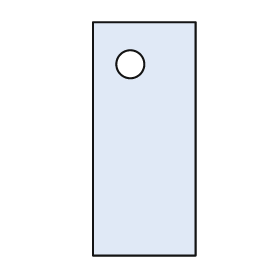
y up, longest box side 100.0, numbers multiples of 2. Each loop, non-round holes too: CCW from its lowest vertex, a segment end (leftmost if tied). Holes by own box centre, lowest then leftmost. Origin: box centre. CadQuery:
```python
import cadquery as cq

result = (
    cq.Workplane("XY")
    .moveTo(-22.0, -50.0)
    .lineTo(22.0, -50.0)
    .lineTo(22.0, 50.0)
    .lineTo(-22.0, 50.0)
    .close()
    .moveTo(-6.0, 32.0)
    .circle(6.0)
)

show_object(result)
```